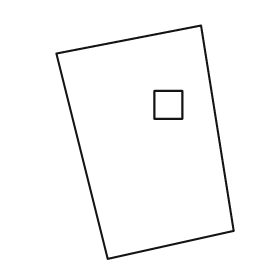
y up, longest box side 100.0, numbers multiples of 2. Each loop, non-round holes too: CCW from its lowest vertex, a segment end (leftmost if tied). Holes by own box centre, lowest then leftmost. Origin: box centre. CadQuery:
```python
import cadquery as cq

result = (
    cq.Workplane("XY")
    .moveTo(-16.0, -50.0)
    .lineTo(38.0, -38.0)
    .lineTo(24.0, 50.0)
    .lineTo(-38.0, 38.0)
    .close()
    .moveTo(4.0, 10.0)
    .lineTo(16.0, 10.0)
    .lineTo(16.0, 22.0)
    .lineTo(4.0, 22.0)
    .close()
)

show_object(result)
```